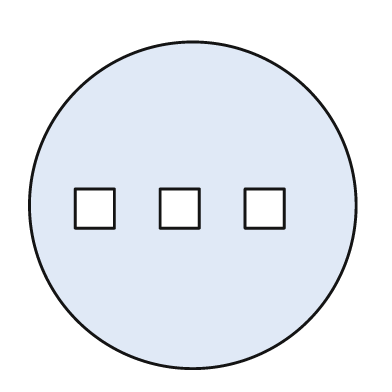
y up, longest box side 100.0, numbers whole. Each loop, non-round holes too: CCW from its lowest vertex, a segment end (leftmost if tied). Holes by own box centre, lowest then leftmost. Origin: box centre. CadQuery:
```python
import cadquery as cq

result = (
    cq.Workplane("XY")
    .moveTo(0.0, 0.0)
    .circle(50.0)
    .moveTo(-36.0, -7.0)
    .lineTo(-24.0, -7.0)
    .lineTo(-24.0, 5.0)
    .lineTo(-36.0, 5.0)
    .close()
    .moveTo(-10.0, -7.0)
    .lineTo(2.0, -7.0)
    .lineTo(2.0, 5.0)
    .lineTo(-10.0, 5.0)
    .close()
    .moveTo(16.0, -7.0)
    .lineTo(28.0, -7.0)
    .lineTo(28.0, 5.0)
    .lineTo(16.0, 5.0)
    .close()
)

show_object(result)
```